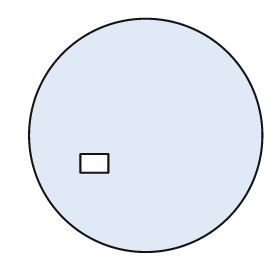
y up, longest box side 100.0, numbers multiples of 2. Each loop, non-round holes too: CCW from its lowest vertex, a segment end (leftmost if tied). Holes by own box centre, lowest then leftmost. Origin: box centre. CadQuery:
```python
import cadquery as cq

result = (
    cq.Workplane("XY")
    .moveTo(0.0, 0.0)
    .circle(50.0)
    .moveTo(-28.0, -16.0)
    .lineTo(-16.0, -16.0)
    .lineTo(-16.0, -8.0)
    .lineTo(-28.0, -8.0)
    .close()
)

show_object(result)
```